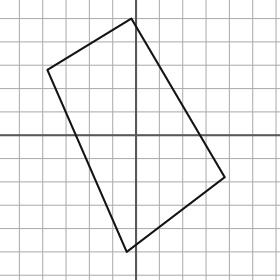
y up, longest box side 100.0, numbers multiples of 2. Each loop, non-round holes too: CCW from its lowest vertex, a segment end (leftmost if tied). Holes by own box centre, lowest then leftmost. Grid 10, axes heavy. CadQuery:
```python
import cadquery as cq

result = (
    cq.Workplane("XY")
    .moveTo(-4.0, -50.0)
    .lineTo(38.0, -18.0)
    .lineTo(-2.0, 50.0)
    .lineTo(-38.0, 28.0)
    .close()
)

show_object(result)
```